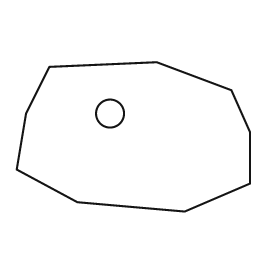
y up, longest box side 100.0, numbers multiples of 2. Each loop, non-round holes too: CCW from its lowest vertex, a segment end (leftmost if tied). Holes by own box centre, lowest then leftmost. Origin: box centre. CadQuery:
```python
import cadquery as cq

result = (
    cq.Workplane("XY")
    .moveTo(22.0, -32.0)
    .lineTo(50.0, -20.0)
    .lineTo(50.0, 2.0)
    .lineTo(42.0, 20.0)
    .lineTo(10.0, 32.0)
    .lineTo(-36.0, 30.0)
    .lineTo(-46.0, 10.0)
    .lineTo(-50.0, -14.0)
    .lineTo(-24.0, -28.0)
    .close()
    .moveTo(-10.0, 10.0)
    .circle(6.0)
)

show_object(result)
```